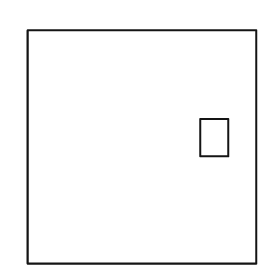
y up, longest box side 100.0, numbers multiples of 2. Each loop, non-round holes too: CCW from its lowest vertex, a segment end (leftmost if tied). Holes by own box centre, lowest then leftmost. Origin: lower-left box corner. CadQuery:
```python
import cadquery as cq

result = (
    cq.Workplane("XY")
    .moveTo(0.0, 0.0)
    .lineTo(98.0, 0.0)
    .lineTo(98.0, 100.0)
    .lineTo(0.0, 100.0)
    .close()
    .moveTo(74.0, 46.0)
    .lineTo(86.0, 46.0)
    .lineTo(86.0, 62.0)
    .lineTo(74.0, 62.0)
    .close()
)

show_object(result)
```